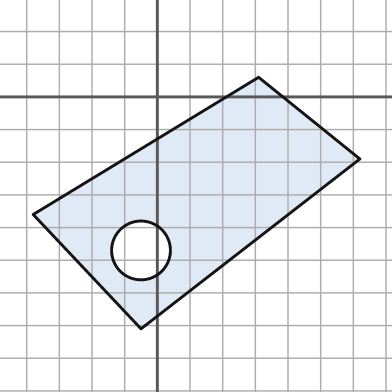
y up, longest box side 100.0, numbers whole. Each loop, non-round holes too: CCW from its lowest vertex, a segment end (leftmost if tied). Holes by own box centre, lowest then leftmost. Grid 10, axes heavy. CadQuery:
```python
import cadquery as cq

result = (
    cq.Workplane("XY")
    .moveTo(-5.0, -71.0)
    .lineTo(62.0, -19.0)
    .lineTo(31.0, 6.0)
    .lineTo(-38.0, -36.0)
    .close()
    .moveTo(-5.0, -47.0)
    .circle(9.0)
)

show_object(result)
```